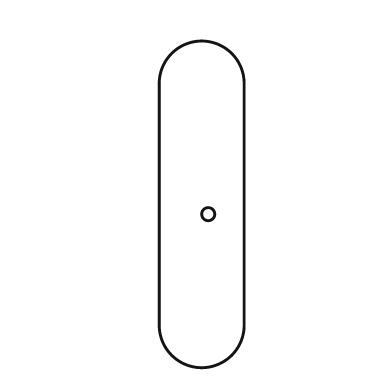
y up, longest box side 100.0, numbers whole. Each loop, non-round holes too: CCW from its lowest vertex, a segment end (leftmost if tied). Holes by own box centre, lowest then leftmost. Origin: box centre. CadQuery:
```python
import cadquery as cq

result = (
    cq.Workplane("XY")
    .moveTo(-13.0, -37.0)
    .threePointArc((0.0, -50.0), (13.0, -37.0))
    .lineTo(13.0, 37.0)
    .threePointArc((0.0, 50.0), (-13.0, 37.0))
    .close()
    .moveTo(2.0, -3.0)
    .circle(2.0)
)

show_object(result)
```